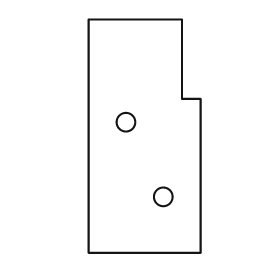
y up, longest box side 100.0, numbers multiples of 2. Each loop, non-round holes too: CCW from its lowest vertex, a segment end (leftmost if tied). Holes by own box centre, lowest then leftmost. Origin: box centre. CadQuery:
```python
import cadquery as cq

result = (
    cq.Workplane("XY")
    .moveTo(-24.0, -50.0)
    .lineTo(24.0, -50.0)
    .lineTo(24.0, 16.0)
    .lineTo(16.0, 16.0)
    .lineTo(16.0, 50.0)
    .lineTo(-24.0, 50.0)
    .close()
    .moveTo(8.0, -26.0)
    .circle(4.0)
    .moveTo(-8.0, 6.0)
    .circle(4.0)
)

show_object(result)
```